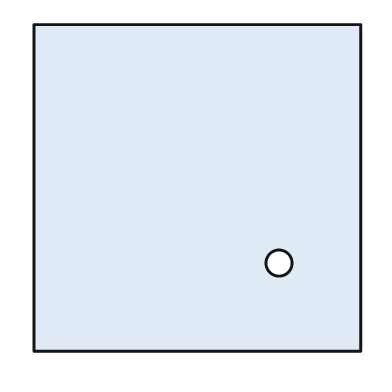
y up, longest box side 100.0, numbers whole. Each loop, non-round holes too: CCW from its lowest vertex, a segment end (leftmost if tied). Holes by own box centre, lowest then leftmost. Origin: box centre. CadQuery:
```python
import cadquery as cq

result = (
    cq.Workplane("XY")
    .moveTo(-50.0, -50.0)
    .lineTo(50.0, -50.0)
    .lineTo(50.0, 50.0)
    .lineTo(-50.0, 50.0)
    .close()
    .moveTo(25.0, -23.0)
    .circle(4.0)
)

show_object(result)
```